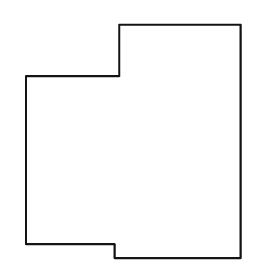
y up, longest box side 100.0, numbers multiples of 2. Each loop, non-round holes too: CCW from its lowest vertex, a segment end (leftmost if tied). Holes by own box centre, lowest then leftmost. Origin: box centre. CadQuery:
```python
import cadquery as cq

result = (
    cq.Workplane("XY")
    .moveTo(-8.0, -50.0)
    .lineTo(46.0, -50.0)
    .lineTo(46.0, 50.0)
    .lineTo(-6.0, 50.0)
    .lineTo(-6.0, 28.0)
    .lineTo(-46.0, 28.0)
    .lineTo(-46.0, -44.0)
    .lineTo(-8.0, -44.0)
    .close()
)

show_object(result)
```